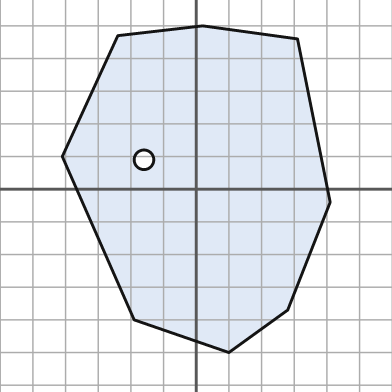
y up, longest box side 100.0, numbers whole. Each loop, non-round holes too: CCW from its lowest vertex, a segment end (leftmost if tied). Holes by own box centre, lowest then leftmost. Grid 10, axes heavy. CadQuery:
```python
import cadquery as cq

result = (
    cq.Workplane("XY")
    .moveTo(10.0, -50.0)
    .lineTo(28.0, -37.0)
    .lineTo(41.0, -4.0)
    .lineTo(31.0, 46.0)
    .lineTo(2.0, 50.0)
    .lineTo(-24.0, 47.0)
    .lineTo(-41.0, 10.0)
    .lineTo(-19.0, -40.0)
    .close()
    .moveTo(-16.0, 9.0)
    .circle(3.0)
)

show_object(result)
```